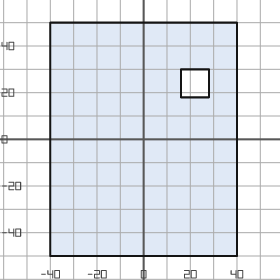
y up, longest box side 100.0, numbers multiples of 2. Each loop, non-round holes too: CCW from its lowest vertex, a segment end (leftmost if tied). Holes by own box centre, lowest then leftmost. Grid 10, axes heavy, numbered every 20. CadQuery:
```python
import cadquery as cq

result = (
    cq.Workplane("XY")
    .moveTo(-40.0, -50.0)
    .lineTo(40.0, -50.0)
    .lineTo(40.0, 50.0)
    .lineTo(-40.0, 50.0)
    .close()
    .moveTo(16.0, 18.0)
    .lineTo(28.0, 18.0)
    .lineTo(28.0, 30.0)
    .lineTo(16.0, 30.0)
    .close()
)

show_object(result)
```